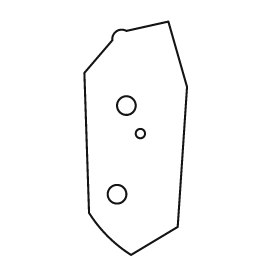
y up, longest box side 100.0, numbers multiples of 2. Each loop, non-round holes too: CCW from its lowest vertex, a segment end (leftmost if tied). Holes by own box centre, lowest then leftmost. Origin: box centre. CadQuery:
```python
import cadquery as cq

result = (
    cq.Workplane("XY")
    .moveTo(-2.0, -50.0)
    .lineTo(18.0, -38.0)
    .lineTo(22.0, 22.0)
    .lineTo(14.0, 50.0)
    .lineTo(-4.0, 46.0)
    .threePointArc((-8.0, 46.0), (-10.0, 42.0))
    .lineTo(-22.0, 28.0)
    .lineTo(-20.0, -32.0)
    .threePointArc((-12.0, -42.0), (-2.0, -50.0))
    .close()
    .moveTo(-8.0, -24.0)
    .circle(4.0)
    .moveTo(2.0, 2.0)
    .circle(2.0)
    .moveTo(-4.0, 14.0)
    .circle(4.0)
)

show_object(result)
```